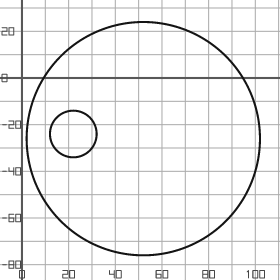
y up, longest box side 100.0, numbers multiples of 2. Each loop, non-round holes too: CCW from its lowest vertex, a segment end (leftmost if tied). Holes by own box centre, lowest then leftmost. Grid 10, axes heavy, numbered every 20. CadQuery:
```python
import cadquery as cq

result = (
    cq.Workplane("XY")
    .moveTo(52.0, -26.0)
    .circle(50.0)
    .moveTo(22.0, -24.0)
    .circle(10.0)
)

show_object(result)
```